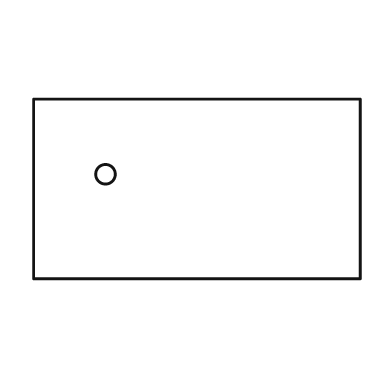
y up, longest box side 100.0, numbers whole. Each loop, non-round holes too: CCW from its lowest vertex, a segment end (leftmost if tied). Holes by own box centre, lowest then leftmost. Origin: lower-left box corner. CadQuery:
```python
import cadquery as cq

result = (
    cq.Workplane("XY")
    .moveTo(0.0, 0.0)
    .lineTo(100.0, 0.0)
    .lineTo(100.0, 55.0)
    .lineTo(0.0, 55.0)
    .close()
    .moveTo(22.0, 32.0)
    .circle(3.0)
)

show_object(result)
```